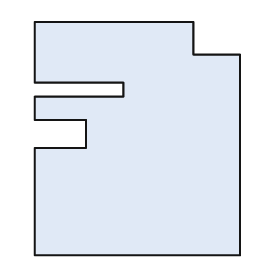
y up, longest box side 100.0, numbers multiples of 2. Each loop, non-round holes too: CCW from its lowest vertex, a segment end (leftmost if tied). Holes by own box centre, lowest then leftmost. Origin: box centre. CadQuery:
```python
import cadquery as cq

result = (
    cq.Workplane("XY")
    .moveTo(-44.0, -50.0)
    .lineTo(44.0, -50.0)
    .lineTo(44.0, 36.0)
    .lineTo(24.0, 36.0)
    .lineTo(24.0, 50.0)
    .lineTo(-44.0, 50.0)
    .lineTo(-44.0, 24.0)
    .lineTo(-6.0, 24.0)
    .lineTo(-6.0, 18.0)
    .lineTo(-44.0, 18.0)
    .lineTo(-44.0, 8.0)
    .lineTo(-22.0, 8.0)
    .lineTo(-22.0, -4.0)
    .lineTo(-44.0, -4.0)
    .close()
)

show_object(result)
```